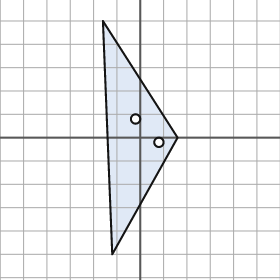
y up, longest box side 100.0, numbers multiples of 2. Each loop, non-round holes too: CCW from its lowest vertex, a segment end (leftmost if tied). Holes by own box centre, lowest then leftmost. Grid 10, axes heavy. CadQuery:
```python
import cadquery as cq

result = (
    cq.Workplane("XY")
    .moveTo(-12.0, -50.0)
    .lineTo(16.0, 0.0)
    .lineTo(-16.0, 50.0)
    .close()
    .moveTo(8.0, -2.0)
    .circle(2.0)
    .moveTo(-2.0, 8.0)
    .circle(2.0)
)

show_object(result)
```